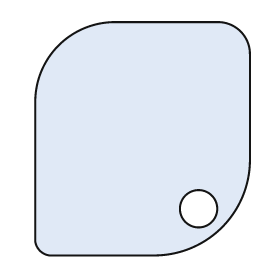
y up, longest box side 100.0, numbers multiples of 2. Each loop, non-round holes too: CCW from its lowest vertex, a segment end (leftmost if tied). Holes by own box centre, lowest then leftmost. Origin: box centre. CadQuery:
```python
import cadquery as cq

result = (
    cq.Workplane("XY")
    .moveTo(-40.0, -50.0)
    .lineTo(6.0, -50.0)
    .threePointArc((34.0, -38.0), (46.0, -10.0))
    .lineTo(46.0, 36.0)
    .threePointArc((42.0, 46.0), (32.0, 50.0))
    .lineTo(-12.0, 50.0)
    .threePointArc((-36.0, 40.0), (-46.0, 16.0))
    .lineTo(-46.0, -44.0)
    .threePointArc((-44.0, -48.0), (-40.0, -50.0))
    .close()
    .moveTo(24.0, -30.0)
    .circle(8.0)
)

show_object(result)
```